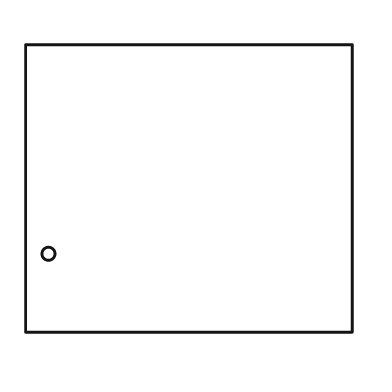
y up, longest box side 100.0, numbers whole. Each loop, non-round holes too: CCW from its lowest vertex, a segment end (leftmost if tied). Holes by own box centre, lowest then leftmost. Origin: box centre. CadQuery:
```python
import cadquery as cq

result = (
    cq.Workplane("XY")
    .moveTo(-50.0, -44.0)
    .lineTo(50.0, -44.0)
    .lineTo(50.0, 44.0)
    .lineTo(-50.0, 44.0)
    .close()
    .moveTo(-43.0, -20.0)
    .circle(2.0)
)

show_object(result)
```